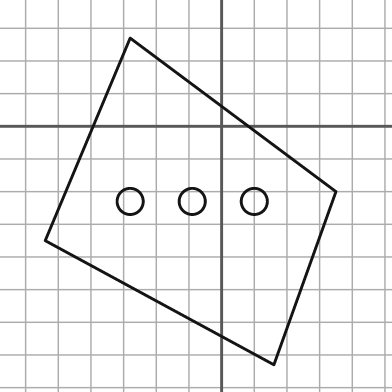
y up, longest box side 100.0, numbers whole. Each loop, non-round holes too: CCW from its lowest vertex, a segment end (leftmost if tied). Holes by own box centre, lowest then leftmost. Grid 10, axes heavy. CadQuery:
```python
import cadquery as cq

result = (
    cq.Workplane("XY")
    .moveTo(16.0, -73.0)
    .lineTo(35.0, -20.0)
    .lineTo(-28.0, 27.0)
    .lineTo(-54.0, -35.0)
    .close()
    .moveTo(-28.0, -23.0)
    .circle(4.0)
    .moveTo(-9.0, -23.0)
    .circle(4.0)
    .moveTo(10.0, -23.0)
    .circle(4.0)
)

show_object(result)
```